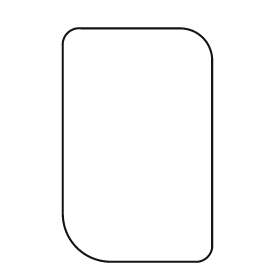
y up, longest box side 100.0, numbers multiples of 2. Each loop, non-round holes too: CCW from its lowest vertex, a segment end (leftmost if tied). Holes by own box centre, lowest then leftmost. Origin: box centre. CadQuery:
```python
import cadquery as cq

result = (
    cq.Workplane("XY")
    .moveTo(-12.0, -50.0)
    .lineTo(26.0, -50.0)
    .threePointArc((30.0, -48.0), (32.0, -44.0))
    .lineTo(32.0, 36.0)
    .threePointArc((28.0, 46.0), (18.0, 50.0))
    .lineTo(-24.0, 50.0)
    .threePointArc((-30.0, 48.0), (-32.0, 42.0))
    .lineTo(-32.0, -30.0)
    .threePointArc((-26.0, -44.0), (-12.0, -50.0))
    .close()
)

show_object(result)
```